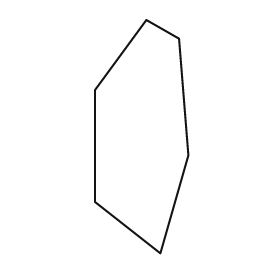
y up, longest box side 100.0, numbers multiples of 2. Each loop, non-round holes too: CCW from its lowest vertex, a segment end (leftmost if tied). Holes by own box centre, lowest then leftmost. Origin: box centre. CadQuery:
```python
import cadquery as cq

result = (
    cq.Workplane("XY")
    .moveTo(8.0, -50.0)
    .lineTo(20.0, -8.0)
    .lineTo(16.0, 42.0)
    .lineTo(2.0, 50.0)
    .lineTo(-20.0, 20.0)
    .lineTo(-20.0, -28.0)
    .close()
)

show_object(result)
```